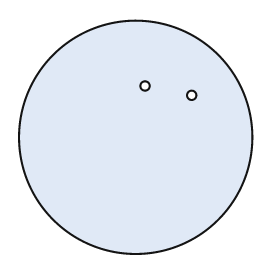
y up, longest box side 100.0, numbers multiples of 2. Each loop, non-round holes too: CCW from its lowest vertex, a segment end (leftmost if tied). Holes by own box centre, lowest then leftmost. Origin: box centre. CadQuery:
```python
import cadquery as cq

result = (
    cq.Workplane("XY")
    .moveTo(0.0, 0.0)
    .circle(50.0)
    .moveTo(24.0, 18.0)
    .circle(2.0)
    .moveTo(4.0, 22.0)
    .circle(2.0)
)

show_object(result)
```